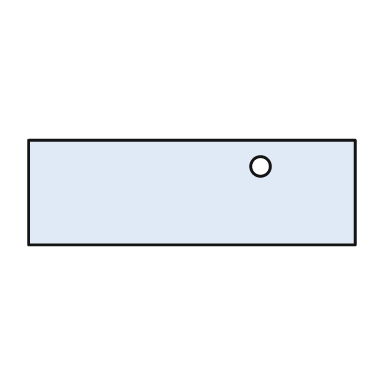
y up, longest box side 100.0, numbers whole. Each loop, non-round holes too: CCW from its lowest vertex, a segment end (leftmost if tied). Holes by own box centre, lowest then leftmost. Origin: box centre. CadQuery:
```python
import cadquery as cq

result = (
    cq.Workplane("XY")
    .moveTo(-50.0, -16.0)
    .lineTo(50.0, -16.0)
    .lineTo(50.0, 16.0)
    .lineTo(-50.0, 16.0)
    .close()
    .moveTo(21.0, 8.0)
    .circle(3.0)
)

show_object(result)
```